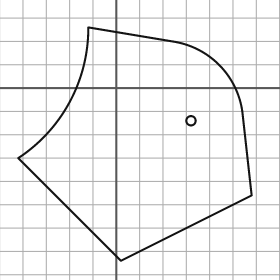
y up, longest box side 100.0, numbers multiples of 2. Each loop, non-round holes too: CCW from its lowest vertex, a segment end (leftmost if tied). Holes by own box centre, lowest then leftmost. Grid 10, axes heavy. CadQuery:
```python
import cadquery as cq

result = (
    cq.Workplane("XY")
    .moveTo(2.0, -74.0)
    .lineTo(58.0, -46.0)
    .lineTo(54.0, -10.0)
    .threePointArc((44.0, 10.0), (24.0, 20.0))
    .lineTo(-12.0, 26.0)
    .threePointArc((-20.0, -6.0), (-42.0, -30.0))
    .close()
    .moveTo(32.0, -14.0)
    .circle(2.0)
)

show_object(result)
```